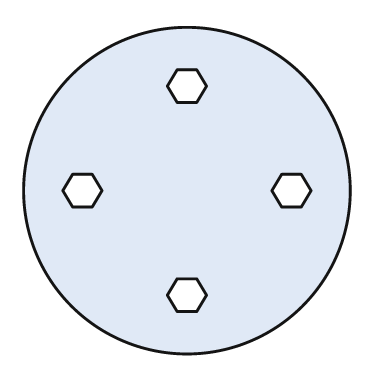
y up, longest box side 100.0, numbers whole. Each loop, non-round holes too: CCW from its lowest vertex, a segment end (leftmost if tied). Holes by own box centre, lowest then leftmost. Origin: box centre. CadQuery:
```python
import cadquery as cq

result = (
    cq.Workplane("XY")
    .moveTo(0.0, 0.0)
    .circle(50.0)
    .moveTo(-3.0, -37.0)
    .lineTo(3.0, -37.0)
    .lineTo(6.0, -32.0)
    .lineTo(3.0, -27.0)
    .lineTo(-3.0, -27.0)
    .lineTo(-6.0, -32.0)
    .close()
    .moveTo(-35.0, -5.0)
    .lineTo(-29.0, -5.0)
    .lineTo(-26.0, 0.0)
    .lineTo(-29.0, 5.0)
    .lineTo(-35.0, 5.0)
    .lineTo(-38.0, 0.0)
    .close()
    .moveTo(29.0, -5.0)
    .lineTo(35.0, -5.0)
    .lineTo(38.0, 0.0)
    .lineTo(35.0, 5.0)
    .lineTo(29.0, 5.0)
    .lineTo(26.0, 0.0)
    .close()
    .moveTo(-3.0, 27.0)
    .lineTo(3.0, 27.0)
    .lineTo(6.0, 32.0)
    .lineTo(3.0, 37.0)
    .lineTo(-3.0, 37.0)
    .lineTo(-6.0, 32.0)
    .close()
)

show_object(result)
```